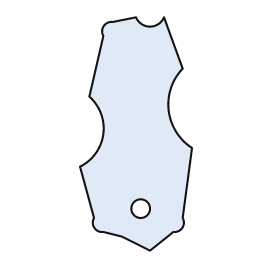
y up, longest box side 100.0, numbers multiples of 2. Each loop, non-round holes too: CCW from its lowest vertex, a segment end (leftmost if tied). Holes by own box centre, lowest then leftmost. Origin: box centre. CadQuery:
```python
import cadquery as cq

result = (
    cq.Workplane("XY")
    .moveTo(6.0, -50.0)
    .lineTo(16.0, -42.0)
    .threePointArc((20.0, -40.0), (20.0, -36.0))
    .lineTo(24.0, -6.0)
    .threePointArc((14.0, 10.0), (20.0, 28.0))
    .lineTo(12.0, 50.0)
    .threePointArc((6.0, 46.0), (0.0, 50.0))
    .lineTo(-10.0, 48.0)
    .threePointArc((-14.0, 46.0), (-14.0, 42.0))
    .lineTo(-20.0, 16.0)
    .threePointArc((-14.0, 0.0), (-24.0, -14.0))
    .lineTo(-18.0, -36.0)
    .threePointArc((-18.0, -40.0), (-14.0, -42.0))
    .lineTo(-6.0, -44.0)
    .close()
    .moveTo(2.0, -32.0)
    .circle(4.0)
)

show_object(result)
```